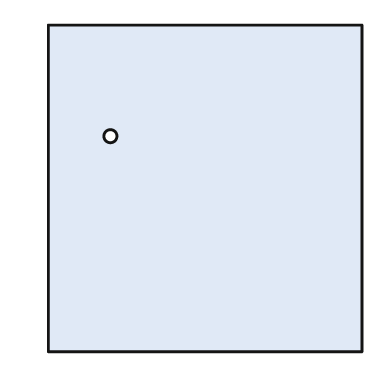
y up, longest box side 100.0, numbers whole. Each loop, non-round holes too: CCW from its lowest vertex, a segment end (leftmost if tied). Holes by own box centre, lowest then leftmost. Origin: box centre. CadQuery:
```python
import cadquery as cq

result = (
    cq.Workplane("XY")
    .moveTo(-48.0, -50.0)
    .lineTo(48.0, -50.0)
    .lineTo(48.0, 50.0)
    .lineTo(-48.0, 50.0)
    .close()
    .moveTo(-29.0, 16.0)
    .circle(2.0)
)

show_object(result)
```